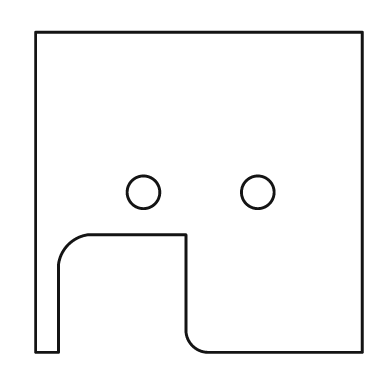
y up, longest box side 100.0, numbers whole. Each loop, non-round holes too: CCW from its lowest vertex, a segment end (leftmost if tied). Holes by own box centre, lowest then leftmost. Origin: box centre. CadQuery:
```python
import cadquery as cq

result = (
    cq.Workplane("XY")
    .moveTo(-50.0, -49.0)
    .lineTo(-43.0, -49.0)
    .lineTo(-43.0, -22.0)
    .threePointArc((-40.0, -16.0), (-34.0, -13.0))
    .lineTo(-4.0, -13.0)
    .lineTo(-4.0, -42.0)
    .threePointArc((-2.0, -47.0), (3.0, -49.0))
    .lineTo(50.0, -49.0)
    .lineTo(50.0, 49.0)
    .lineTo(-50.0, 49.0)
    .close()
    .moveTo(-17.0, 0.0)
    .circle(5.0)
    .moveTo(18.0, 0.0)
    .circle(5.0)
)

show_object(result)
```